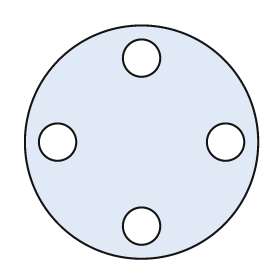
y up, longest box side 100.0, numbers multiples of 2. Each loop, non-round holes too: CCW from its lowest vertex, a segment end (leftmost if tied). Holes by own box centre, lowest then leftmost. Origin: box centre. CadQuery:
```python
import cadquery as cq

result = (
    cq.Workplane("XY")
    .moveTo(0.0, 0.0)
    .circle(50.0)
    .moveTo(0.0, -36.0)
    .circle(8.0)
    .moveTo(-36.0, 0.0)
    .circle(8.0)
    .moveTo(36.0, 0.0)
    .circle(8.0)
    .moveTo(0.0, 36.0)
    .circle(8.0)
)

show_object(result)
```